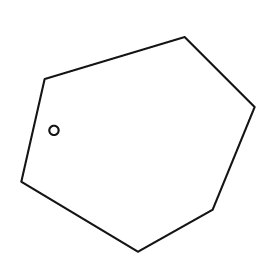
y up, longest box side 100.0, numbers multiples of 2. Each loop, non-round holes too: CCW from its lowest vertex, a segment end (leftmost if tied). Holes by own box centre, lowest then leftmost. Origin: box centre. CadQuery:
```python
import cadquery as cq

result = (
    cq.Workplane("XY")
    .moveTo(0.0, -46.0)
    .lineTo(32.0, -28.0)
    .lineTo(50.0, 16.0)
    .lineTo(20.0, 46.0)
    .lineTo(-40.0, 28.0)
    .lineTo(-50.0, -16.0)
    .close()
    .moveTo(-36.0, 6.0)
    .circle(2.0)
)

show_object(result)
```